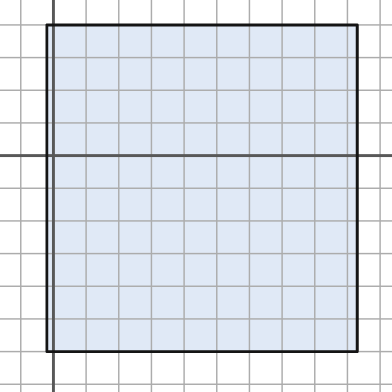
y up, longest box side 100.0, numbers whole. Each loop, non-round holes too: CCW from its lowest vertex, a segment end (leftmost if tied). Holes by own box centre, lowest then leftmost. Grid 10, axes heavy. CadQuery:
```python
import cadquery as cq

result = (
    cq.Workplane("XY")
    .moveTo(-2.0, -60.0)
    .lineTo(93.0, -60.0)
    .lineTo(93.0, 40.0)
    .lineTo(-2.0, 40.0)
    .close()
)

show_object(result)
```